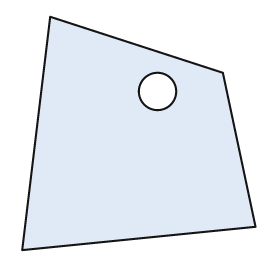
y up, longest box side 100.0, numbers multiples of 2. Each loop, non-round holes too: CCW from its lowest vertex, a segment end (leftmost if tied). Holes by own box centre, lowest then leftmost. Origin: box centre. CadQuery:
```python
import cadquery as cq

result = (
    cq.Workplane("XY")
    .moveTo(-50.0, -50.0)
    .lineTo(50.0, -40.0)
    .lineTo(36.0, 26.0)
    .lineTo(-38.0, 50.0)
    .close()
    .moveTo(8.0, 18.0)
    .circle(8.0)
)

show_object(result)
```